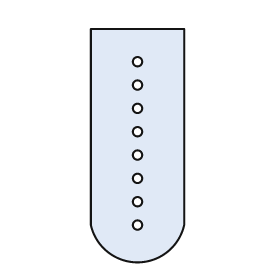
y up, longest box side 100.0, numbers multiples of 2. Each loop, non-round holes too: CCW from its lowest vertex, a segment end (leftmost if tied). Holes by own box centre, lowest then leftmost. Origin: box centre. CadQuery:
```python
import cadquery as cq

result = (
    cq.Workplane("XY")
    .moveTo(-20.0, -34.0)
    .threePointArc((0.0, -50.0), (20.0, -34.0))
    .lineTo(20.0, 50.0)
    .lineTo(-20.0, 50.0)
    .close()
    .moveTo(0.0, -34.0)
    .circle(2.0)
    .moveTo(0.0, -24.0)
    .circle(2.0)
    .moveTo(0.0, -14.0)
    .circle(2.0)
    .moveTo(0.0, -4.0)
    .circle(2.0)
    .moveTo(0.0, 6.0)
    .circle(2.0)
    .moveTo(0.0, 16.0)
    .circle(2.0)
    .moveTo(0.0, 26.0)
    .circle(2.0)
    .moveTo(0.0, 36.0)
    .circle(2.0)
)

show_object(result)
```